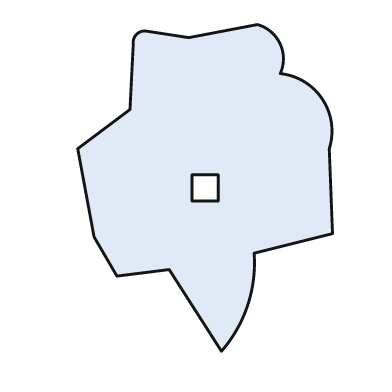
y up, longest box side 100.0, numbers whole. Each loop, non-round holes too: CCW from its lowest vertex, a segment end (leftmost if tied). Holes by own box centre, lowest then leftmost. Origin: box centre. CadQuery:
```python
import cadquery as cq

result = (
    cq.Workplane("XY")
    .moveTo(5.0, -50.0)
    .threePointArc((13.0, -36.0), (15.0, -20.0))
    .lineTo(39.0, -14.0)
    .lineTo(38.0, 12.0)
    .threePointArc((36.0, 27.0), (23.0, 35.0))
    .threePointArc((23.0, 44.0), (16.0, 50.0))
    .lineTo(-5.0, 46.0)
    .lineTo(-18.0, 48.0)
    .threePointArc((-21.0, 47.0), (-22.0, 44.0))
    .lineTo(-23.0, 24.0)
    .lineTo(-39.0, 12.0)
    .lineTo(-34.0, -15.0)
    .lineTo(-27.0, -27.0)
    .lineTo(-11.0, -25.0)
    .close()
    .moveTo(-4.0, -4.0)
    .lineTo(4.0, -4.0)
    .lineTo(4.0, 4.0)
    .lineTo(-4.0, 4.0)
    .close()
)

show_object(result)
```